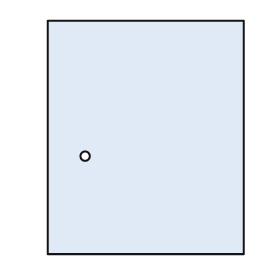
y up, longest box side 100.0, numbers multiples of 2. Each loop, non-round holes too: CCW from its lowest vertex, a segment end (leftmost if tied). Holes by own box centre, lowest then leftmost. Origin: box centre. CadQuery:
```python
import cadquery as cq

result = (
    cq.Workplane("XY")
    .moveTo(-42.0, -50.0)
    .lineTo(42.0, -50.0)
    .lineTo(42.0, 50.0)
    .lineTo(-42.0, 50.0)
    .close()
    .moveTo(-26.0, -8.0)
    .circle(2.0)
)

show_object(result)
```